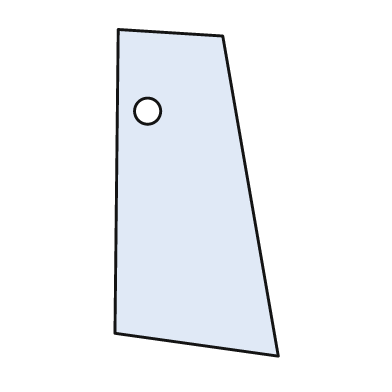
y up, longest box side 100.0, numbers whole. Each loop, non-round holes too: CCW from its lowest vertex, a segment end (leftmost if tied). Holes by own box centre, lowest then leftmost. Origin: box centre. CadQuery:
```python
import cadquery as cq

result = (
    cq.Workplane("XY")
    .moveTo(25.0, -50.0)
    .lineTo(8.0, 48.0)
    .lineTo(-24.0, 50.0)
    .lineTo(-25.0, -43.0)
    .close()
    .moveTo(-15.0, 25.0)
    .circle(4.0)
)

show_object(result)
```